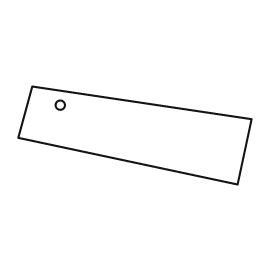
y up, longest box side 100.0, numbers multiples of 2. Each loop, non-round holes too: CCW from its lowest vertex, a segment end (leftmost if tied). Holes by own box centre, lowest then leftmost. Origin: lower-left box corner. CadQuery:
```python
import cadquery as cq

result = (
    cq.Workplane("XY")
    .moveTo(94.0, 0.0)
    .lineTo(100.0, 28.0)
    .lineTo(6.0, 42.0)
    .lineTo(0.0, 20.0)
    .close()
    .moveTo(18.0, 34.0)
    .circle(2.0)
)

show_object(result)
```